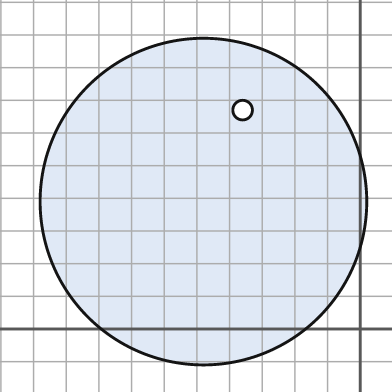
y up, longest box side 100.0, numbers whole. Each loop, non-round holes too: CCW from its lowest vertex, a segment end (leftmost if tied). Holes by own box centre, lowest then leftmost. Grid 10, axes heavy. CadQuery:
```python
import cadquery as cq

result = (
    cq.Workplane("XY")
    .moveTo(-48.0, 39.0)
    .circle(50.0)
    .moveTo(-36.0, 67.0)
    .circle(3.0)
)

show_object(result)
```